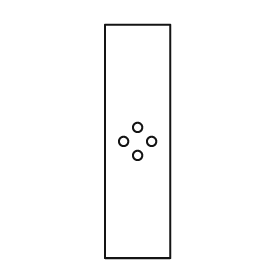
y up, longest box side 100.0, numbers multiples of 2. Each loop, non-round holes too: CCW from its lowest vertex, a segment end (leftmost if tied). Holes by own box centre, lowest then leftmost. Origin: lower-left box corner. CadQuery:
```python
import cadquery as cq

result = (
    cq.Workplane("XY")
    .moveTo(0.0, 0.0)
    .lineTo(28.0, 0.0)
    .lineTo(28.0, 100.0)
    .lineTo(0.0, 100.0)
    .close()
    .moveTo(14.0, 44.0)
    .circle(2.0)
    .moveTo(8.0, 50.0)
    .circle(2.0)
    .moveTo(20.0, 50.0)
    .circle(2.0)
    .moveTo(14.0, 56.0)
    .circle(2.0)
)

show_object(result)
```